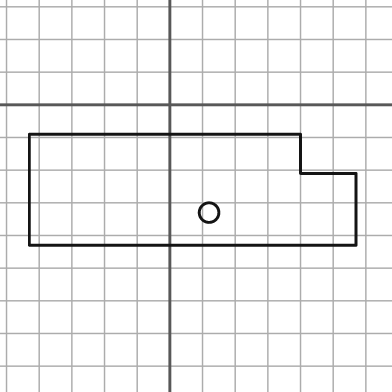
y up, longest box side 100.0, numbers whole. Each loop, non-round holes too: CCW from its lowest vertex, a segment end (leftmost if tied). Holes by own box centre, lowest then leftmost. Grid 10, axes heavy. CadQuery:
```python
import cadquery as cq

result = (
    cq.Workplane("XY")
    .moveTo(-43.0, -43.0)
    .lineTo(57.0, -43.0)
    .lineTo(57.0, -21.0)
    .lineTo(40.0, -21.0)
    .lineTo(40.0, -9.0)
    .lineTo(-43.0, -9.0)
    .close()
    .moveTo(12.0, -33.0)
    .circle(3.0)
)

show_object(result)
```